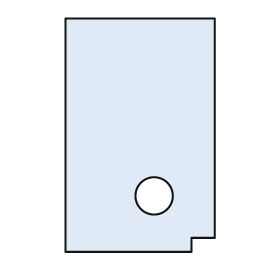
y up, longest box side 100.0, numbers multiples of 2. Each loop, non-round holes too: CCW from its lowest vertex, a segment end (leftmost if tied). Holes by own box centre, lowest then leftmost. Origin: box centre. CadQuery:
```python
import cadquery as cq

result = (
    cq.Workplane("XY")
    .moveTo(-32.0, -50.0)
    .lineTo(22.0, -50.0)
    .lineTo(22.0, -44.0)
    .lineTo(32.0, -44.0)
    .lineTo(32.0, 50.0)
    .lineTo(-32.0, 50.0)
    .close()
    .moveTo(6.0, -26.0)
    .circle(8.0)
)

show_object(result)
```